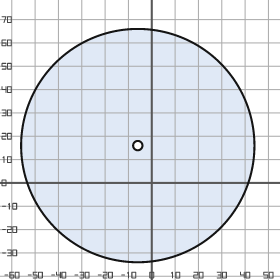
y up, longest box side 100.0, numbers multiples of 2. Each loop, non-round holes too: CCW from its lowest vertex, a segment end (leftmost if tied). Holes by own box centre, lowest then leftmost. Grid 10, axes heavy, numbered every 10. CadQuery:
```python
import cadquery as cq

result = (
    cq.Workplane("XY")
    .moveTo(-6.0, 16.0)
    .circle(50.0)
    .moveTo(-6.0, 16.0)
    .circle(2.0)
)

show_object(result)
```